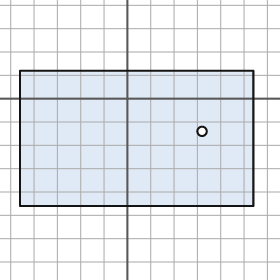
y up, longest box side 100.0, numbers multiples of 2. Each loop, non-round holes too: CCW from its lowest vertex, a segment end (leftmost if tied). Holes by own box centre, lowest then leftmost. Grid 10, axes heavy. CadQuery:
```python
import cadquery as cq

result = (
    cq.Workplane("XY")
    .moveTo(-46.0, -46.0)
    .lineTo(54.0, -46.0)
    .lineTo(54.0, 12.0)
    .lineTo(-46.0, 12.0)
    .close()
    .moveTo(32.0, -14.0)
    .circle(2.0)
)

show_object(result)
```